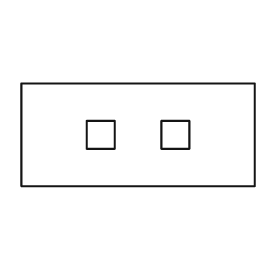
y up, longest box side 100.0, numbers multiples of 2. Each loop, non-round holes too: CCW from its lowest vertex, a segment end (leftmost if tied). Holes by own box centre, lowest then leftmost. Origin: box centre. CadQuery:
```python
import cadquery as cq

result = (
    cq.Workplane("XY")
    .moveTo(-50.0, -22.0)
    .lineTo(50.0, -22.0)
    .lineTo(50.0, 22.0)
    .lineTo(-50.0, 22.0)
    .close()
    .moveTo(-22.0, -6.0)
    .lineTo(-10.0, -6.0)
    .lineTo(-10.0, 6.0)
    .lineTo(-22.0, 6.0)
    .close()
    .moveTo(10.0, -6.0)
    .lineTo(22.0, -6.0)
    .lineTo(22.0, 6.0)
    .lineTo(10.0, 6.0)
    .close()
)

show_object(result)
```